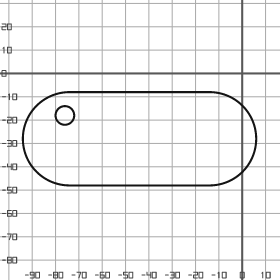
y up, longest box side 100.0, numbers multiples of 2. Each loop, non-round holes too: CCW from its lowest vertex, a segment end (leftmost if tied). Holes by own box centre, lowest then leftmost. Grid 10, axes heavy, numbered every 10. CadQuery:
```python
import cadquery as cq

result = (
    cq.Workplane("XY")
    .moveTo(-74.0, -48.0)
    .lineTo(-14.0, -48.0)
    .threePointArc((6.0, -28.0), (-14.0, -8.0))
    .lineTo(-74.0, -8.0)
    .threePointArc((-94.0, -28.0), (-74.0, -48.0))
    .close()
    .moveTo(-76.0, -18.0)
    .circle(4.0)
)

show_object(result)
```